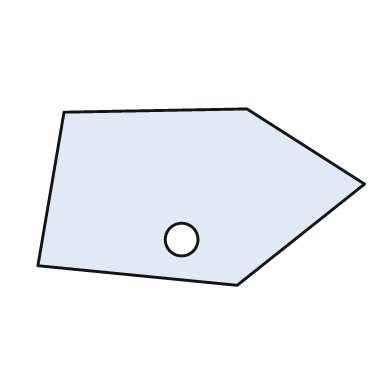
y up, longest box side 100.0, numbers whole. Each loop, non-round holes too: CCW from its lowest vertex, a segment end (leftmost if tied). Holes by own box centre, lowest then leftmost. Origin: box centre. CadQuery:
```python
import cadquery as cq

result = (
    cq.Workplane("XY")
    .moveTo(11.0, -27.0)
    .lineTo(50.0, 4.0)
    .lineTo(14.0, 27.0)
    .lineTo(-42.0, 26.0)
    .lineTo(-50.0, -21.0)
    .close()
    .moveTo(-6.0, -13.0)
    .circle(5.0)
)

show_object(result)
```